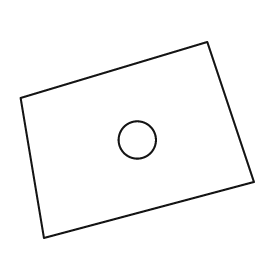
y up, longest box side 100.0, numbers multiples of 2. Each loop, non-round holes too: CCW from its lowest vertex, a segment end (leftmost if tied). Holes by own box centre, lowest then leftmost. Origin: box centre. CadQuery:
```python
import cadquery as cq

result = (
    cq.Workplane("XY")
    .moveTo(-40.0, -42.0)
    .lineTo(50.0, -18.0)
    .lineTo(30.0, 42.0)
    .lineTo(-50.0, 18.0)
    .close()
    .moveTo(0.0, 0.0)
    .circle(8.0)
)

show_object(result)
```